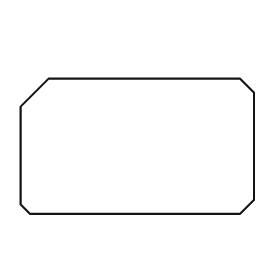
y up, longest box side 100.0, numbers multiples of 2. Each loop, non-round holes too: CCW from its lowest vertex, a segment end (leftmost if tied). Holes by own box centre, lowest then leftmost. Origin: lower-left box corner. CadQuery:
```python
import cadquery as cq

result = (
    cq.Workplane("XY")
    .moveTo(4.0, 0.0)
    .lineTo(94.0, 0.0)
    .lineTo(100.0, 6.0)
    .lineTo(100.0, 52.0)
    .lineTo(94.0, 58.0)
    .lineTo(12.0, 58.0)
    .lineTo(0.0, 46.0)
    .lineTo(0.0, 4.0)
    .close()
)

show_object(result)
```